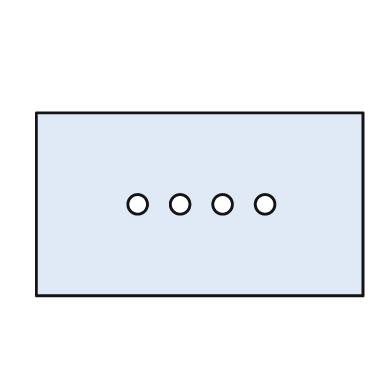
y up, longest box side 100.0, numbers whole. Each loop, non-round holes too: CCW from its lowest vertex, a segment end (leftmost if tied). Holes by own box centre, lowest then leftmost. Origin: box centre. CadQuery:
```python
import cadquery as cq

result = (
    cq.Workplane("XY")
    .moveTo(-50.0, -28.0)
    .lineTo(50.0, -28.0)
    .lineTo(50.0, 28.0)
    .lineTo(-50.0, 28.0)
    .close()
    .moveTo(-19.0, 0.0)
    .circle(3.0)
    .moveTo(-6.0, 0.0)
    .circle(3.0)
    .moveTo(7.0, 0.0)
    .circle(3.0)
    .moveTo(20.0, 0.0)
    .circle(3.0)
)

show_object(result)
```